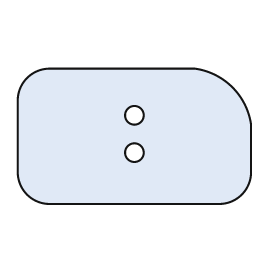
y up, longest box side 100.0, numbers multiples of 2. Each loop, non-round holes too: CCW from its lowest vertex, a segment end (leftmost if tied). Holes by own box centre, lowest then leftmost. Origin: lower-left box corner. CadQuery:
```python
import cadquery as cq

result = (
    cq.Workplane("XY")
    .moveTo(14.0, 0.0)
    .lineTo(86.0, 0.0)
    .threePointArc((96.0, 4.0), (100.0, 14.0))
    .lineTo(100.0, 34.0)
    .threePointArc((92.0, 50.0), (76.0, 58.0))
    .lineTo(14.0, 58.0)
    .threePointArc((4.0, 54.0), (0.0, 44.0))
    .lineTo(0.0, 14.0)
    .threePointArc((4.0, 4.0), (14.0, 0.0))
    .close()
    .moveTo(50.0, 22.0)
    .circle(4.0)
    .moveTo(50.0, 38.0)
    .circle(4.0)
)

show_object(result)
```